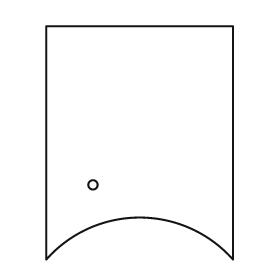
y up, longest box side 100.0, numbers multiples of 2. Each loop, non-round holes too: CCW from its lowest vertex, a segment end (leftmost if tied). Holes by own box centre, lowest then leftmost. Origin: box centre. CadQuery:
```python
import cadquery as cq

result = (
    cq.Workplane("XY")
    .moveTo(-40.0, -50.0)
    .threePointArc((0.0, -32.0), (40.0, -50.0))
    .lineTo(40.0, 50.0)
    .lineTo(-40.0, 50.0)
    .close()
    .moveTo(-20.0, -18.0)
    .circle(2.0)
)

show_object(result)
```